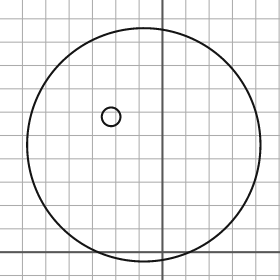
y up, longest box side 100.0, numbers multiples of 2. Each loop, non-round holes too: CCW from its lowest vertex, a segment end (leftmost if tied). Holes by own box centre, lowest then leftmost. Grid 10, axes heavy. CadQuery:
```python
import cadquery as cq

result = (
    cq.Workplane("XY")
    .moveTo(-8.0, 46.0)
    .circle(50.0)
    .moveTo(-22.0, 58.0)
    .circle(4.0)
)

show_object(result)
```